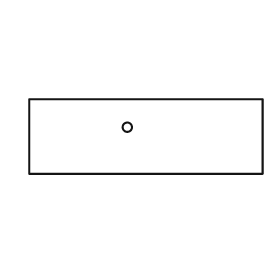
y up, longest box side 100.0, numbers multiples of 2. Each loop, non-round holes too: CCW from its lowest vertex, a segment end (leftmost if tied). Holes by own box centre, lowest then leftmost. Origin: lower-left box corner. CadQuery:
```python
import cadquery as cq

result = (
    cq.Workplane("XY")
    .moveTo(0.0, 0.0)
    .lineTo(100.0, 0.0)
    .lineTo(100.0, 32.0)
    .lineTo(0.0, 32.0)
    .close()
    .moveTo(42.0, 20.0)
    .circle(2.0)
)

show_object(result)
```